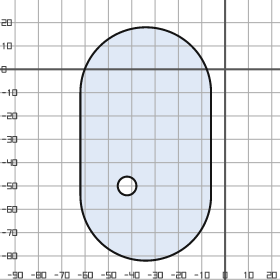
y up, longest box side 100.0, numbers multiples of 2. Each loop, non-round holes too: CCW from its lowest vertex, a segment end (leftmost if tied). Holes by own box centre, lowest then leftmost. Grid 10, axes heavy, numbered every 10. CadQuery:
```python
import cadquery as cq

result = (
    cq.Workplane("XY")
    .moveTo(-62.0, -54.0)
    .threePointArc((-34.0, -82.0), (-6.0, -54.0))
    .lineTo(-6.0, -10.0)
    .threePointArc((-34.0, 18.0), (-62.0, -10.0))
    .close()
    .moveTo(-42.0, -50.0)
    .circle(4.0)
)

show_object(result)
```